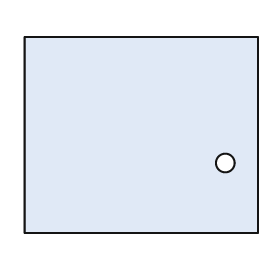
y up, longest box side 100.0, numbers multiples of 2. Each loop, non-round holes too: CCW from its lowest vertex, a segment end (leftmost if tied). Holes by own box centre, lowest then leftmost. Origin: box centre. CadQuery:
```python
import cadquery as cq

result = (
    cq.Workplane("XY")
    .moveTo(-50.0, -42.0)
    .lineTo(50.0, -42.0)
    .lineTo(50.0, 42.0)
    .lineTo(-50.0, 42.0)
    .close()
    .moveTo(36.0, -12.0)
    .circle(4.0)
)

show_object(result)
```